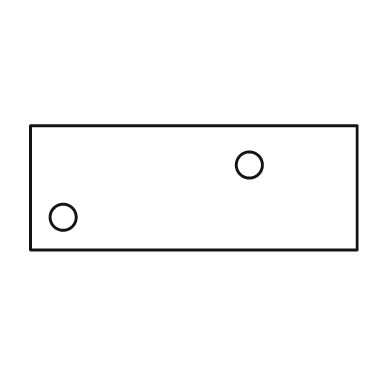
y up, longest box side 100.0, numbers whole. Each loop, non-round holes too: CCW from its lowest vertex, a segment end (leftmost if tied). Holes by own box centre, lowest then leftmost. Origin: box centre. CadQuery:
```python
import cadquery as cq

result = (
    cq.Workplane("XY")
    .moveTo(-50.0, -19.0)
    .lineTo(50.0, -19.0)
    .lineTo(50.0, 19.0)
    .lineTo(-50.0, 19.0)
    .close()
    .moveTo(-40.0, -9.0)
    .circle(4.0)
    .moveTo(17.0, 7.0)
    .circle(4.0)
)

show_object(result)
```